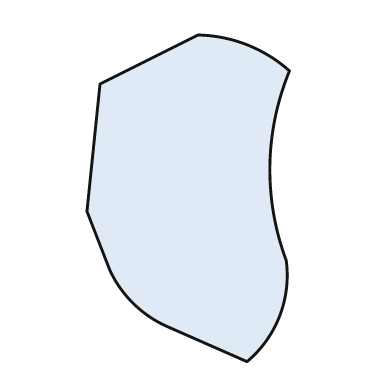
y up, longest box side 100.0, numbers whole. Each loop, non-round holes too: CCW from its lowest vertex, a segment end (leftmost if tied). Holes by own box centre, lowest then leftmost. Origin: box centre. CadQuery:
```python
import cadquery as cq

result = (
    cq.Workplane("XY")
    .moveTo(18.0, -50.0)
    .threePointArc((28.0, -36.0), (30.0, -19.0))
    .threePointArc((25.0, 10.0), (31.0, 39.0))
    .threePointArc((18.0, 47.0), (3.0, 50.0))
    .lineTo(-27.0, 35.0)
    .lineTo(-31.0, -4.0)
    .lineTo(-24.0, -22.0)
    .threePointArc((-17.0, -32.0), (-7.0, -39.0))
    .close()
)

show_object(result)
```